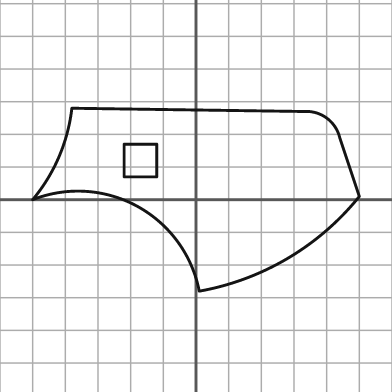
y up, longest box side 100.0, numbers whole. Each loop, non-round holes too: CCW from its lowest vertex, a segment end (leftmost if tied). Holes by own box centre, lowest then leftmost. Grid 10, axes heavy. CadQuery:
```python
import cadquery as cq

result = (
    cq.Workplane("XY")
    .moveTo(1.0, -28.0)
    .threePointArc((28.0, -18.0), (50.0, 1.0))
    .lineTo(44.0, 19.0)
    .threePointArc((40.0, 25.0), (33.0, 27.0))
    .lineTo(-38.0, 28.0)
    .threePointArc((-42.0, 13.0), (-50.0, 0.0))
    .threePointArc((-18.0, -2.0), (1.0, -28.0))
    .close()
    .moveTo(-22.0, 7.0)
    .lineTo(-12.0, 7.0)
    .lineTo(-12.0, 17.0)
    .lineTo(-22.0, 17.0)
    .close()
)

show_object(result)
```